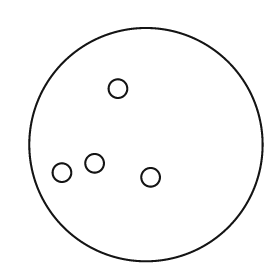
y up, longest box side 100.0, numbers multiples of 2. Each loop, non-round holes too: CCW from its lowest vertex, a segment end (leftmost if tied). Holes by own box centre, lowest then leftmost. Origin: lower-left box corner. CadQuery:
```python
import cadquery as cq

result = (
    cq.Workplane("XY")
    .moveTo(50.0, 50.0)
    .circle(50.0)
    .moveTo(52.0, 36.0)
    .circle(4.0)
    .moveTo(14.0, 38.0)
    .circle(4.0)
    .moveTo(28.0, 42.0)
    .circle(4.0)
    .moveTo(38.0, 74.0)
    .circle(4.0)
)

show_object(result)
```